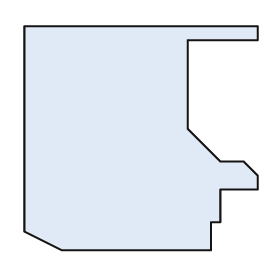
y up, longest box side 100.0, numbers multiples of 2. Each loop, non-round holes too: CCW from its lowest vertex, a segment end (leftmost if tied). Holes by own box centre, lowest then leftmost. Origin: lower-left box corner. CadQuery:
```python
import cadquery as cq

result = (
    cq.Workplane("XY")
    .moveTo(16.0, 0.0)
    .lineTo(80.0, 0.0)
    .lineTo(80.0, 12.0)
    .lineTo(84.0, 12.0)
    .lineTo(84.0, 26.0)
    .lineTo(100.0, 26.0)
    .lineTo(100.0, 32.0)
    .lineTo(94.0, 38.0)
    .lineTo(84.0, 38.0)
    .lineTo(70.0, 52.0)
    .lineTo(70.0, 90.0)
    .lineTo(100.0, 90.0)
    .lineTo(100.0, 96.0)
    .lineTo(0.0, 96.0)
    .lineTo(0.0, 8.0)
    .close()
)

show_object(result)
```